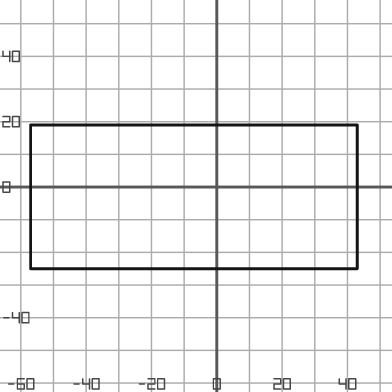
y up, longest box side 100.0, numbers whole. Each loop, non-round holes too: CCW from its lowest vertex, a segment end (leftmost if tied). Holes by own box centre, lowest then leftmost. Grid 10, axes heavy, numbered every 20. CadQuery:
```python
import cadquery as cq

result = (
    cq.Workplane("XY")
    .moveTo(-57.0, -25.0)
    .lineTo(43.0, -25.0)
    .lineTo(43.0, 19.0)
    .lineTo(-57.0, 19.0)
    .close()
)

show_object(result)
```